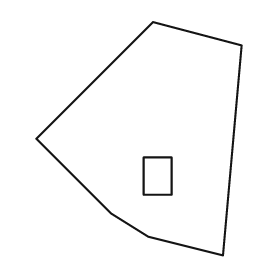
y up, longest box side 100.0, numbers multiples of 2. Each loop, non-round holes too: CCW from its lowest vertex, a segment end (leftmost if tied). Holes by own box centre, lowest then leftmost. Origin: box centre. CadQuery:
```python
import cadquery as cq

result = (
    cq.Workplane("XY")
    .moveTo(36.0, -50.0)
    .lineTo(44.0, 40.0)
    .lineTo(6.0, 50.0)
    .lineTo(-44.0, 0.0)
    .lineTo(-12.0, -32.0)
    .lineTo(4.0, -42.0)
    .close()
    .moveTo(2.0, -24.0)
    .lineTo(14.0, -24.0)
    .lineTo(14.0, -8.0)
    .lineTo(2.0, -8.0)
    .close()
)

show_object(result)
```